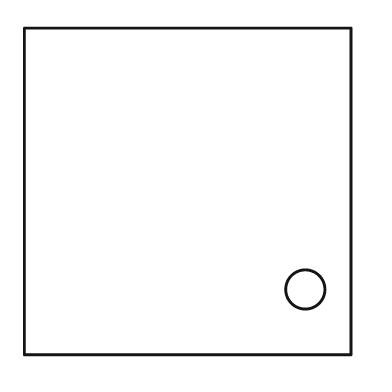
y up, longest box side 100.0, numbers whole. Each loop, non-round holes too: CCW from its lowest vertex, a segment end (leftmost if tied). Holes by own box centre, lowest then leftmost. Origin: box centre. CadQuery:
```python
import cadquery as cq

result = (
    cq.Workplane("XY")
    .moveTo(-50.0, -50.0)
    .lineTo(50.0, -50.0)
    .lineTo(50.0, 50.0)
    .lineTo(-50.0, 50.0)
    .close()
    .moveTo(36.0, -30.0)
    .circle(6.0)
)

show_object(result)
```